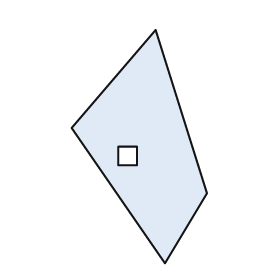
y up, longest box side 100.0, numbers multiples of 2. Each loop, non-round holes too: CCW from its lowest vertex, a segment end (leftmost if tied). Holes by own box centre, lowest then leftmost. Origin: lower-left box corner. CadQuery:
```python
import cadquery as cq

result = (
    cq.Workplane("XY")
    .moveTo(40.0, 0.0)
    .lineTo(58.0, 30.0)
    .lineTo(36.0, 100.0)
    .lineTo(0.0, 58.0)
    .close()
    .moveTo(20.0, 42.0)
    .lineTo(28.0, 42.0)
    .lineTo(28.0, 50.0)
    .lineTo(20.0, 50.0)
    .close()
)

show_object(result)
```